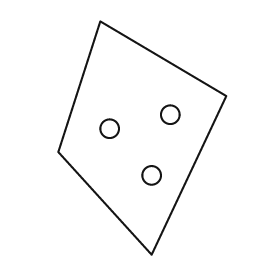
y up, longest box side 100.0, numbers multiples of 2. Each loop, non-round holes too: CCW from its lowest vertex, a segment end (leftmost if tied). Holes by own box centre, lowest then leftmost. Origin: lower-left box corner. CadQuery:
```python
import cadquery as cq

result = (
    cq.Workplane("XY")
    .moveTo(40.0, 0.0)
    .lineTo(72.0, 68.0)
    .lineTo(18.0, 100.0)
    .lineTo(0.0, 44.0)
    .close()
    .moveTo(40.0, 34.0)
    .circle(4.0)
    .moveTo(22.0, 54.0)
    .circle(4.0)
    .moveTo(48.0, 60.0)
    .circle(4.0)
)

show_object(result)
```